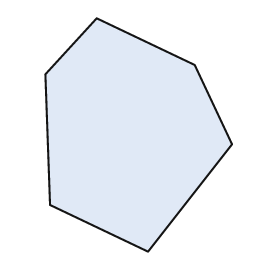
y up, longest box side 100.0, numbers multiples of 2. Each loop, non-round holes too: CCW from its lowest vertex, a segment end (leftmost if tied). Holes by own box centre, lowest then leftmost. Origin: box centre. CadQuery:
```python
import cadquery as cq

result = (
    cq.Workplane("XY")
    .moveTo(4.0, -50.0)
    .lineTo(40.0, -4.0)
    .lineTo(24.0, 30.0)
    .lineTo(-18.0, 50.0)
    .lineTo(-40.0, 26.0)
    .lineTo(-38.0, -30.0)
    .close()
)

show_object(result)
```